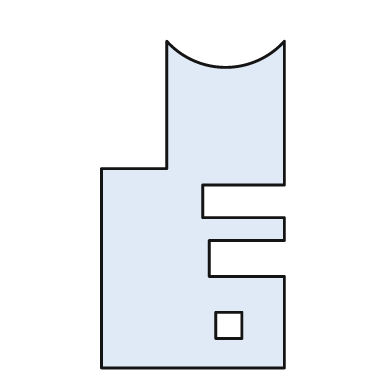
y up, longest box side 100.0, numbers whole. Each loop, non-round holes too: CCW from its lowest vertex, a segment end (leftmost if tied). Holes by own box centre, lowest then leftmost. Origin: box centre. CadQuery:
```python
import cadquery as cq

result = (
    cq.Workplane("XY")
    .moveTo(-28.0, -50.0)
    .lineTo(28.0, -50.0)
    .lineTo(28.0, -22.0)
    .lineTo(5.0, -22.0)
    .lineTo(5.0, -11.0)
    .lineTo(28.0, -11.0)
    .lineTo(28.0, -4.0)
    .lineTo(3.0, -4.0)
    .lineTo(3.0, 6.0)
    .lineTo(28.0, 6.0)
    .lineTo(28.0, 50.0)
    .threePointArc((10.0, 42.0), (-8.0, 50.0))
    .lineTo(-8.0, 11.0)
    .lineTo(-28.0, 11.0)
    .close()
    .moveTo(7.0, -41.0)
    .lineTo(15.0, -41.0)
    .lineTo(15.0, -33.0)
    .lineTo(7.0, -33.0)
    .close()
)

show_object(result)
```